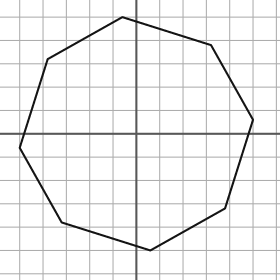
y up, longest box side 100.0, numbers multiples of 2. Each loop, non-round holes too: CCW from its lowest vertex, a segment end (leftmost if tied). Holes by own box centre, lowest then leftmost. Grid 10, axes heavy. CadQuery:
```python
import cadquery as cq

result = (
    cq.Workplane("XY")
    .moveTo(6.0, -50.0)
    .lineTo(38.0, -32.0)
    .lineTo(50.0, 6.0)
    .lineTo(32.0, 38.0)
    .lineTo(-6.0, 50.0)
    .lineTo(-38.0, 32.0)
    .lineTo(-50.0, -6.0)
    .lineTo(-32.0, -38.0)
    .close()
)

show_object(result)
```